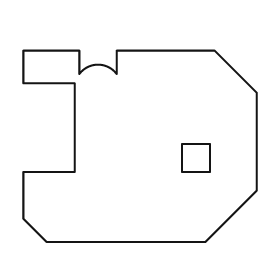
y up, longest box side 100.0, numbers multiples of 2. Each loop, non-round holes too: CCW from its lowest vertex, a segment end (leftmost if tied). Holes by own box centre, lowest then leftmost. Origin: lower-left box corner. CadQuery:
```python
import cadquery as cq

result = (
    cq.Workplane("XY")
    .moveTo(10.0, 0.0)
    .lineTo(78.0, 0.0)
    .lineTo(100.0, 22.0)
    .lineTo(100.0, 64.0)
    .lineTo(82.0, 82.0)
    .lineTo(40.0, 82.0)
    .lineTo(40.0, 72.0)
    .threePointArc((32.0, 76.0), (24.0, 72.0))
    .lineTo(24.0, 82.0)
    .lineTo(0.0, 82.0)
    .lineTo(0.0, 68.0)
    .lineTo(22.0, 68.0)
    .lineTo(22.0, 30.0)
    .lineTo(0.0, 30.0)
    .lineTo(0.0, 10.0)
    .close()
    .moveTo(68.0, 30.0)
    .lineTo(80.0, 30.0)
    .lineTo(80.0, 42.0)
    .lineTo(68.0, 42.0)
    .close()
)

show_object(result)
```